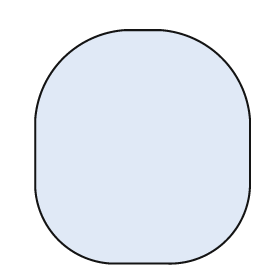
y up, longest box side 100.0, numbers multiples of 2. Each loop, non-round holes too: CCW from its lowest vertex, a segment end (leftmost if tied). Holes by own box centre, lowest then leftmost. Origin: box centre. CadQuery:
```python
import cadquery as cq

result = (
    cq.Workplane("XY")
    .moveTo(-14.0, -50.0)
    .lineTo(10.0, -50.0)
    .threePointArc((36.0, -40.0), (46.0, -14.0))
    .lineTo(46.0, 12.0)
    .threePointArc((34.0, 38.0), (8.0, 50.0))
    .lineTo(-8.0, 50.0)
    .threePointArc((-34.0, 38.0), (-46.0, 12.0))
    .lineTo(-46.0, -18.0)
    .threePointArc((-36.0, -40.0), (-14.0, -50.0))
    .close()
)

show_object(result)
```